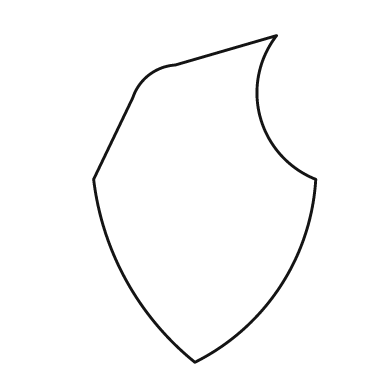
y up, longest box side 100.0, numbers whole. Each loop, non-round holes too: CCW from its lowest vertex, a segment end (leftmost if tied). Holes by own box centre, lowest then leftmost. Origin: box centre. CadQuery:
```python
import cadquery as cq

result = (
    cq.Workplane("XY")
    .moveTo(-3.0, -50.0)
    .threePointArc((23.0, -27.0), (34.0, 6.0))
    .threePointArc((17.0, 25.0), (22.0, 50.0))
    .lineTo(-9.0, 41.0)
    .threePointArc((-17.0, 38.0), (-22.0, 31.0))
    .lineTo(-34.0, 6.0)
    .threePointArc((-24.0, -25.0), (-3.0, -50.0))
    .close()
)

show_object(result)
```